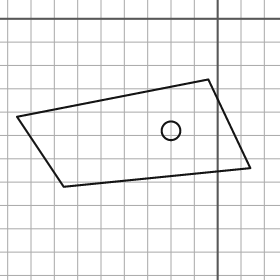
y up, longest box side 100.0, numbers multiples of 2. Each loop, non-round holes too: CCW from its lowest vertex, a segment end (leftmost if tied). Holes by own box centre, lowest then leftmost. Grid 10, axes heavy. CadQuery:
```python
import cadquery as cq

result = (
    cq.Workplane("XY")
    .moveTo(-66.0, -72.0)
    .lineTo(14.0, -64.0)
    .lineTo(-4.0, -26.0)
    .lineTo(-86.0, -42.0)
    .close()
    .moveTo(-20.0, -48.0)
    .circle(4.0)
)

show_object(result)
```